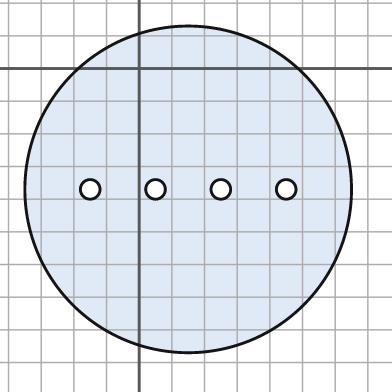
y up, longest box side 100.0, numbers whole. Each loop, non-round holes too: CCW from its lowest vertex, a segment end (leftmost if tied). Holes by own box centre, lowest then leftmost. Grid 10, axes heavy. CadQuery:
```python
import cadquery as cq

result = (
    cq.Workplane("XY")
    .moveTo(15.0, -37.0)
    .circle(50.0)
    .moveTo(-15.0, -37.0)
    .circle(3.0)
    .moveTo(5.0, -37.0)
    .circle(3.0)
    .moveTo(25.0, -37.0)
    .circle(3.0)
    .moveTo(45.0, -37.0)
    .circle(3.0)
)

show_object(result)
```